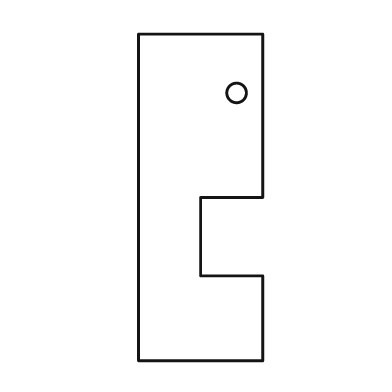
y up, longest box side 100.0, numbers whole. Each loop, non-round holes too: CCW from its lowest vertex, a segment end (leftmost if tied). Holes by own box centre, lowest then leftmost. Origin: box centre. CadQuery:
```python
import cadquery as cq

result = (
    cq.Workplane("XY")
    .moveTo(-19.0, -50.0)
    .lineTo(19.0, -50.0)
    .lineTo(19.0, -24.0)
    .lineTo(0.0, -24.0)
    .lineTo(0.0, 0.0)
    .lineTo(19.0, 0.0)
    .lineTo(19.0, 50.0)
    .lineTo(-19.0, 50.0)
    .close()
    .moveTo(11.0, 32.0)
    .circle(3.0)
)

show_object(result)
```